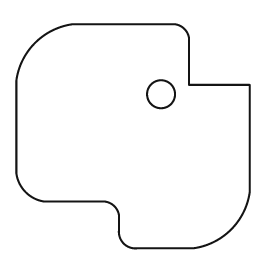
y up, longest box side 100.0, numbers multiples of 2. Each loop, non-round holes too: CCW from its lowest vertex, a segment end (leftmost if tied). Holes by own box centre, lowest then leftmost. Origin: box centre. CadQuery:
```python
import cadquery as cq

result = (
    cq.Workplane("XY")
    .moveTo(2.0, -48.0)
    .lineTo(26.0, -48.0)
    .threePointArc((42.0, -40.0), (50.0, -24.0))
    .lineTo(50.0, 22.0)
    .lineTo(24.0, 22.0)
    .lineTo(24.0, 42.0)
    .threePointArc((22.0, 46.0), (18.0, 48.0))
    .lineTo(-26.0, 48.0)
    .threePointArc((-42.0, 40.0), (-50.0, 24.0))
    .lineTo(-50.0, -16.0)
    .threePointArc((-46.0, -24.0), (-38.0, -28.0))
    .lineTo(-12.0, -28.0)
    .threePointArc((-8.0, -30.0), (-6.0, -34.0))
    .lineTo(-6.0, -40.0)
    .threePointArc((-4.0, -46.0), (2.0, -48.0))
    .close()
    .moveTo(12.0, 18.0)
    .circle(6.0)
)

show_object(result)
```